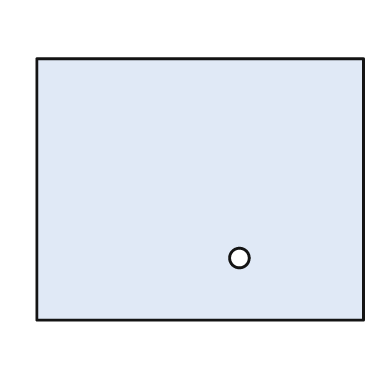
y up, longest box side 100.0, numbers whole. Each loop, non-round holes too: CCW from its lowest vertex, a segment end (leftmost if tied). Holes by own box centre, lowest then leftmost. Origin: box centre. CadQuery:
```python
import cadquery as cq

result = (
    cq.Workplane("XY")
    .moveTo(-50.0, -40.0)
    .lineTo(50.0, -40.0)
    .lineTo(50.0, 40.0)
    .lineTo(-50.0, 40.0)
    .close()
    .moveTo(12.0, -21.0)
    .circle(3.0)
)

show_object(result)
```